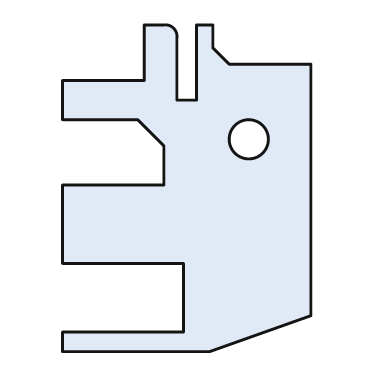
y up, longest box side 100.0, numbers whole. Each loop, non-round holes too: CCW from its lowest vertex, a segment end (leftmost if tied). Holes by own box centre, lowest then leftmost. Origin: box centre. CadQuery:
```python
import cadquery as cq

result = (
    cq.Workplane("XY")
    .moveTo(-38.0, -50.0)
    .lineTo(7.0, -50.0)
    .lineTo(38.0, -39.0)
    .lineTo(38.0, 38.0)
    .lineTo(13.0, 38.0)
    .lineTo(8.0, 43.0)
    .lineTo(8.0, 50.0)
    .lineTo(3.0, 50.0)
    .lineTo(3.0, 27.0)
    .lineTo(-3.0, 27.0)
    .lineTo(-3.0, 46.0)
    .threePointArc((-4.0, 49.0), (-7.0, 50.0))
    .lineTo(-13.0, 50.0)
    .lineTo(-13.0, 33.0)
    .lineTo(-38.0, 33.0)
    .lineTo(-38.0, 21.0)
    .lineTo(-15.0, 21.0)
    .lineTo(-7.0, 13.0)
    .lineTo(-7.0, 1.0)
    .lineTo(-38.0, 1.0)
    .lineTo(-38.0, -23.0)
    .lineTo(-1.0, -23.0)
    .lineTo(-1.0, -44.0)
    .lineTo(-38.0, -44.0)
    .close()
    .moveTo(19.0, 15.0)
    .circle(6.0)
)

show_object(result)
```